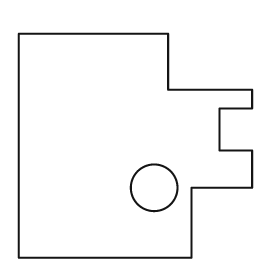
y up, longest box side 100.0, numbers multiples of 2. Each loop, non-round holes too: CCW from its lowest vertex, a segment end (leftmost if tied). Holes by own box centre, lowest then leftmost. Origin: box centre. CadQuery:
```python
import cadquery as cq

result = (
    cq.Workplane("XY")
    .moveTo(-50.0, -48.0)
    .lineTo(24.0, -48.0)
    .lineTo(24.0, -18.0)
    .lineTo(50.0, -18.0)
    .lineTo(50.0, -2.0)
    .lineTo(36.0, -2.0)
    .lineTo(36.0, 16.0)
    .lineTo(50.0, 16.0)
    .lineTo(50.0, 24.0)
    .lineTo(14.0, 24.0)
    .lineTo(14.0, 48.0)
    .lineTo(-50.0, 48.0)
    .close()
    .moveTo(8.0, -18.0)
    .circle(10.0)
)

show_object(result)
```